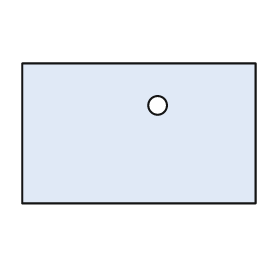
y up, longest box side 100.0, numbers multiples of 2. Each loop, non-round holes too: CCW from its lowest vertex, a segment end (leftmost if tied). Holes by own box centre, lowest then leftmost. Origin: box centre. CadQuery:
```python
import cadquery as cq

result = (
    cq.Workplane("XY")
    .moveTo(-50.0, -30.0)
    .lineTo(50.0, -30.0)
    .lineTo(50.0, 30.0)
    .lineTo(-50.0, 30.0)
    .close()
    .moveTo(8.0, 12.0)
    .circle(4.0)
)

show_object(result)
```